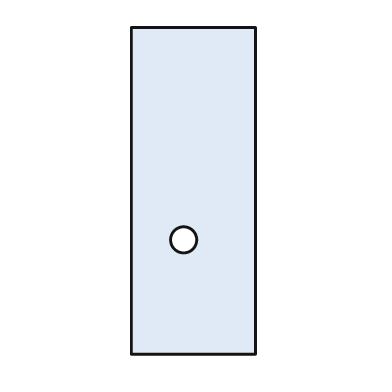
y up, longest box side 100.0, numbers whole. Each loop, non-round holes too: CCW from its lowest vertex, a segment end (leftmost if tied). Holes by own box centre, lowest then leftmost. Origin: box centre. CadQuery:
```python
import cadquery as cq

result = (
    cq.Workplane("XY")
    .moveTo(-19.0, -50.0)
    .lineTo(19.0, -50.0)
    .lineTo(19.0, 50.0)
    .lineTo(-19.0, 50.0)
    .close()
    .moveTo(-3.0, -15.0)
    .circle(4.0)
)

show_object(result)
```